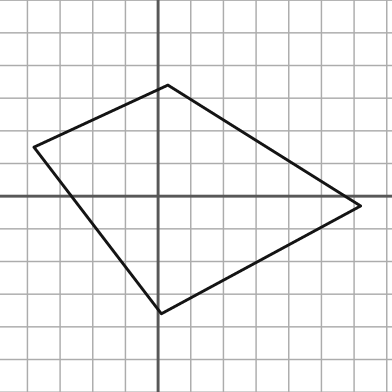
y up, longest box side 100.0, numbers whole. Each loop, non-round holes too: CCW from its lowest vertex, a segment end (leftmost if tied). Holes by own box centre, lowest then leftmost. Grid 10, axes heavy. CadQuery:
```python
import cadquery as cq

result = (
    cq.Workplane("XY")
    .moveTo(1.0, -36.0)
    .lineTo(62.0, -3.0)
    .lineTo(3.0, 34.0)
    .lineTo(-38.0, 15.0)
    .close()
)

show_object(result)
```